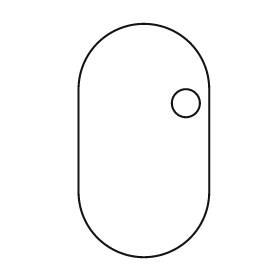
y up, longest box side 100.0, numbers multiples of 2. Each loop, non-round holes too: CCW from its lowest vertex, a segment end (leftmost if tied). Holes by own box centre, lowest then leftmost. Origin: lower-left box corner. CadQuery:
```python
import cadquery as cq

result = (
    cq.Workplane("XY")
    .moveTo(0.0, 28.0)
    .threePointArc((28.0, 0.0), (56.0, 28.0))
    .lineTo(56.0, 72.0)
    .threePointArc((28.0, 100.0), (0.0, 72.0))
    .close()
    .moveTo(46.0, 66.0)
    .circle(6.0)
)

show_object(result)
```